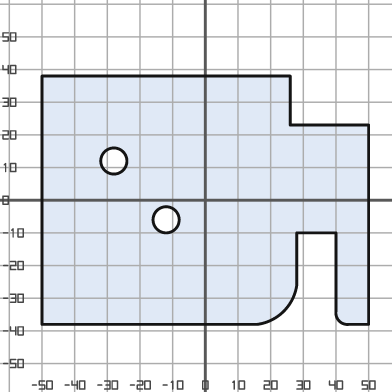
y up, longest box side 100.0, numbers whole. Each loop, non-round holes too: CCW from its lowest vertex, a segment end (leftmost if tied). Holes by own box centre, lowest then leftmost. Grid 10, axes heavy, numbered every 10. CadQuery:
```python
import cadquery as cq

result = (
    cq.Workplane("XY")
    .moveTo(-50.0, -38.0)
    .lineTo(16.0, -38.0)
    .threePointArc((24.0, -34.0), (28.0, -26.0))
    .lineTo(28.0, -10.0)
    .lineTo(40.0, -10.0)
    .lineTo(40.0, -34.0)
    .threePointArc((41.0, -37.0), (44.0, -38.0))
    .lineTo(50.0, -38.0)
    .lineTo(50.0, 23.0)
    .lineTo(26.0, 23.0)
    .lineTo(26.0, 38.0)
    .lineTo(-50.0, 38.0)
    .close()
    .moveTo(-12.0, -6.0)
    .circle(4.0)
    .moveTo(-28.0, 12.0)
    .circle(4.0)
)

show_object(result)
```